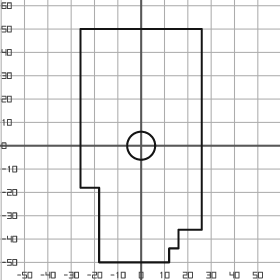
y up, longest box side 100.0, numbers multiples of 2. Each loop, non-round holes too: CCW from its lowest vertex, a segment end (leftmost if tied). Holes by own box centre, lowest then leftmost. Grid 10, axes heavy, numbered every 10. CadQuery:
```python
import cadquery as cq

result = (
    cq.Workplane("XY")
    .moveTo(-18.0, -50.0)
    .lineTo(12.0, -50.0)
    .lineTo(12.0, -44.0)
    .lineTo(16.0, -44.0)
    .lineTo(16.0, -36.0)
    .lineTo(26.0, -36.0)
    .lineTo(26.0, 50.0)
    .lineTo(-26.0, 50.0)
    .lineTo(-26.0, -18.0)
    .lineTo(-18.0, -18.0)
    .close()
    .moveTo(0.0, 0.0)
    .circle(6.0)
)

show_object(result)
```